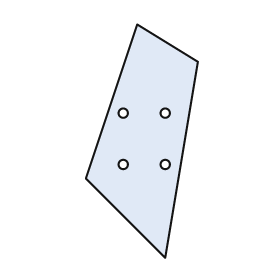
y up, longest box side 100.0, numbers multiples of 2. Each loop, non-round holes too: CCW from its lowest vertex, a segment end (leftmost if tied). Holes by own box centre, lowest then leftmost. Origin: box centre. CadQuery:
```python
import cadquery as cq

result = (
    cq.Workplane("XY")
    .moveTo(10.0, -50.0)
    .lineTo(24.0, 34.0)
    .lineTo(-2.0, 50.0)
    .lineTo(-24.0, -16.0)
    .close()
    .moveTo(-8.0, -10.0)
    .circle(2.0)
    .moveTo(10.0, -10.0)
    .circle(2.0)
    .moveTo(-8.0, 12.0)
    .circle(2.0)
    .moveTo(10.0, 12.0)
    .circle(2.0)
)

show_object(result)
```